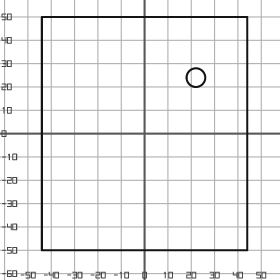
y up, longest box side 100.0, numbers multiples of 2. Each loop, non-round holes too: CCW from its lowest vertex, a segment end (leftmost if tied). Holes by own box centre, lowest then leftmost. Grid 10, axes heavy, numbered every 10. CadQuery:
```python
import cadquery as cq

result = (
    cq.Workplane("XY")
    .moveTo(-44.0, -50.0)
    .lineTo(44.0, -50.0)
    .lineTo(44.0, 50.0)
    .lineTo(-44.0, 50.0)
    .close()
    .moveTo(22.0, 24.0)
    .circle(4.0)
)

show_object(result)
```